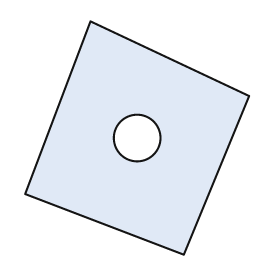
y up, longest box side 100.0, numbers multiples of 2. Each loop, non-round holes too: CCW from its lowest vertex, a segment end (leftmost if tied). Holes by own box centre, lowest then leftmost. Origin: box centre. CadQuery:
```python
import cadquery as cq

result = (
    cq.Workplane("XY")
    .moveTo(20.0, -50.0)
    .lineTo(48.0, 18.0)
    .lineTo(-20.0, 50.0)
    .lineTo(-48.0, -24.0)
    .close()
    .moveTo(0.0, 0.0)
    .circle(10.0)
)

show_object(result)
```